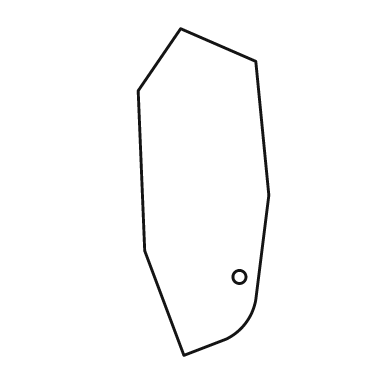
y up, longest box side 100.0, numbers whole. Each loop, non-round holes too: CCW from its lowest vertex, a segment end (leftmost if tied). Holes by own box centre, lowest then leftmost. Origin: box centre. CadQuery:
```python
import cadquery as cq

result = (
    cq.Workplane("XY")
    .moveTo(-6.0, -50.0)
    .lineTo(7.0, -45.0)
    .threePointArc((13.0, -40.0), (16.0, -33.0))
    .lineTo(20.0, -1.0)
    .lineTo(16.0, 40.0)
    .lineTo(-7.0, 50.0)
    .lineTo(-20.0, 31.0)
    .lineTo(-18.0, -18.0)
    .close()
    .moveTo(11.0, -26.0)
    .circle(2.0)
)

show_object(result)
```